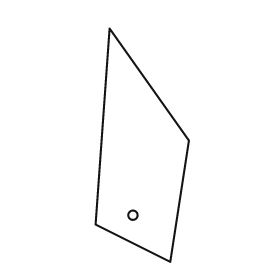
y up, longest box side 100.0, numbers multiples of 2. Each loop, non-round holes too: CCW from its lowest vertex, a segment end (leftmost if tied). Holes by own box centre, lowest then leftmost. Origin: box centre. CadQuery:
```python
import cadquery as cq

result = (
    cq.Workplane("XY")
    .moveTo(12.0, -50.0)
    .lineTo(20.0, 2.0)
    .lineTo(-14.0, 50.0)
    .lineTo(-20.0, -34.0)
    .close()
    .moveTo(-4.0, -30.0)
    .circle(2.0)
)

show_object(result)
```